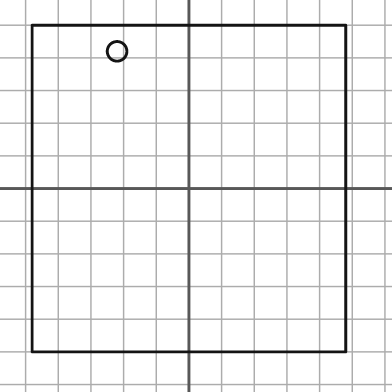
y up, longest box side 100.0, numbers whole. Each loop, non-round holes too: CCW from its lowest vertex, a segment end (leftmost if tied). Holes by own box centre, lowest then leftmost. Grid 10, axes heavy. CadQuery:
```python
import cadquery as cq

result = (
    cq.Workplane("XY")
    .moveTo(-48.0, -50.0)
    .lineTo(48.0, -50.0)
    .lineTo(48.0, 50.0)
    .lineTo(-48.0, 50.0)
    .close()
    .moveTo(-22.0, 42.0)
    .circle(3.0)
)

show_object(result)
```